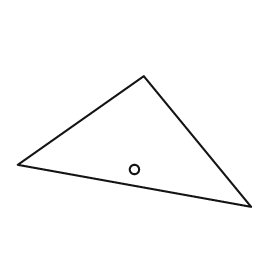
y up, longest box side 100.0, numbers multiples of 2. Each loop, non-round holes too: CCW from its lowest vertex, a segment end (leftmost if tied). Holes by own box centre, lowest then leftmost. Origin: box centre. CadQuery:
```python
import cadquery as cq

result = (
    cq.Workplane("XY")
    .moveTo(50.0, -28.0)
    .lineTo(4.0, 28.0)
    .lineTo(-50.0, -10.0)
    .close()
    .moveTo(0.0, -12.0)
    .circle(2.0)
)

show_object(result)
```